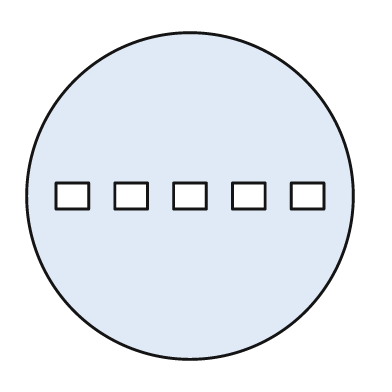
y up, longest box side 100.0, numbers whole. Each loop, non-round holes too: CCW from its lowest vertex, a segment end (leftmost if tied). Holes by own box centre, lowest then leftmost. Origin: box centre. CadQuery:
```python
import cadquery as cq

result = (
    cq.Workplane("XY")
    .moveTo(0.0, 0.0)
    .circle(50.0)
    .moveTo(-41.0, -4.0)
    .lineTo(-31.0, -4.0)
    .lineTo(-31.0, 4.0)
    .lineTo(-41.0, 4.0)
    .close()
    .moveTo(-23.0, -4.0)
    .lineTo(-13.0, -4.0)
    .lineTo(-13.0, 4.0)
    .lineTo(-23.0, 4.0)
    .close()
    .moveTo(-5.0, -4.0)
    .lineTo(5.0, -4.0)
    .lineTo(5.0, 4.0)
    .lineTo(-5.0, 4.0)
    .close()
    .moveTo(13.0, -4.0)
    .lineTo(23.0, -4.0)
    .lineTo(23.0, 4.0)
    .lineTo(13.0, 4.0)
    .close()
    .moveTo(31.0, -4.0)
    .lineTo(41.0, -4.0)
    .lineTo(41.0, 4.0)
    .lineTo(31.0, 4.0)
    .close()
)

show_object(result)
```